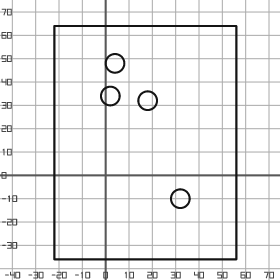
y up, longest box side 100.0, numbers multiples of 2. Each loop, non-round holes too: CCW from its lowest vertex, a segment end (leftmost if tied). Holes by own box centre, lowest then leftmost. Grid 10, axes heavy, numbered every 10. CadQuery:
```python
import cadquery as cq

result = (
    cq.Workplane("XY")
    .moveTo(-22.0, -36.0)
    .lineTo(56.0, -36.0)
    .lineTo(56.0, 64.0)
    .lineTo(-22.0, 64.0)
    .close()
    .moveTo(32.0, -10.0)
    .circle(4.0)
    .moveTo(18.0, 32.0)
    .circle(4.0)
    .moveTo(2.0, 34.0)
    .circle(4.0)
    .moveTo(4.0, 48.0)
    .circle(4.0)
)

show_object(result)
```